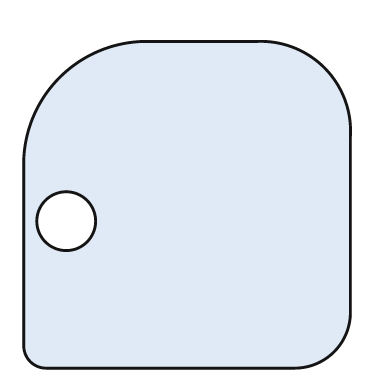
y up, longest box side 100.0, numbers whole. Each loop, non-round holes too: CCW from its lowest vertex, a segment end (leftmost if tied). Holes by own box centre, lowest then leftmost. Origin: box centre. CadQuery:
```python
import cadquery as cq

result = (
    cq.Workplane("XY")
    .moveTo(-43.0, -50.0)
    .lineTo(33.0, -50.0)
    .threePointArc((45.0, -45.0), (50.0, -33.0))
    .lineTo(50.0, 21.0)
    .threePointArc((42.0, 42.0), (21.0, 50.0))
    .lineTo(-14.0, 50.0)
    .threePointArc((-39.0, 39.0), (-50.0, 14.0))
    .lineTo(-50.0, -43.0)
    .threePointArc((-48.0, -48.0), (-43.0, -50.0))
    .close()
    .moveTo(-37.0, -5.0)
    .circle(9.0)
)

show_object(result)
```